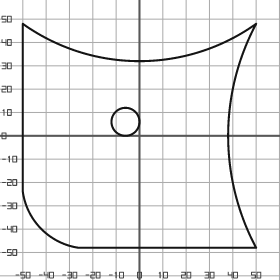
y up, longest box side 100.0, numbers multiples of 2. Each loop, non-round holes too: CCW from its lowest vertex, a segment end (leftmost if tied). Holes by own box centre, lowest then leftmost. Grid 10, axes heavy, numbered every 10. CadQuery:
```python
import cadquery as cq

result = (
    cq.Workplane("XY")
    .moveTo(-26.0, -48.0)
    .lineTo(50.0, -48.0)
    .threePointArc((38.0, 0.0), (50.0, 48.0))
    .threePointArc((0.0, 32.0), (-50.0, 48.0))
    .lineTo(-50.0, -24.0)
    .threePointArc((-42.0, -40.0), (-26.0, -48.0))
    .close()
    .moveTo(-6.0, 6.0)
    .circle(6.0)
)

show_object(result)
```